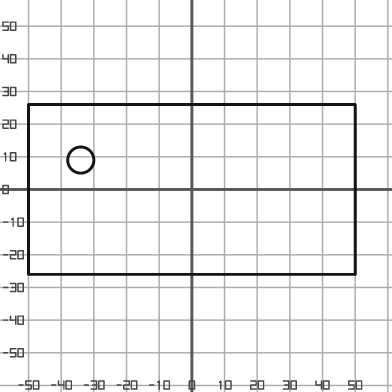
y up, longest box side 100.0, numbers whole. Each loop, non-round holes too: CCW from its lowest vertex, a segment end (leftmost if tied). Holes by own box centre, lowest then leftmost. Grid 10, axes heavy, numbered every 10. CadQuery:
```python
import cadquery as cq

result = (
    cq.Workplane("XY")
    .moveTo(-50.0, -26.0)
    .lineTo(50.0, -26.0)
    .lineTo(50.0, 26.0)
    .lineTo(-50.0, 26.0)
    .close()
    .moveTo(-34.0, 9.0)
    .circle(4.0)
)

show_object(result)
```